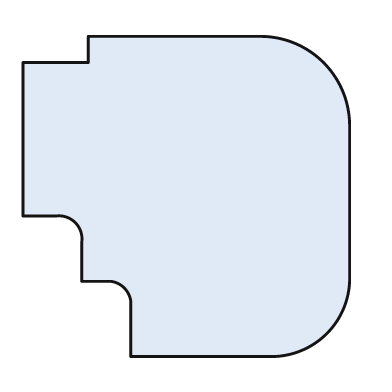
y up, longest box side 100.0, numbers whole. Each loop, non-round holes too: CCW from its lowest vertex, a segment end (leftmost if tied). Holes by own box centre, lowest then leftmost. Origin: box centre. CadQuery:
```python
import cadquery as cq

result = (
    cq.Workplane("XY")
    .moveTo(-17.0, -49.0)
    .lineTo(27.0, -49.0)
    .threePointArc((43.0, -42.0), (50.0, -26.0))
    .lineTo(50.0, 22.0)
    .threePointArc((42.0, 41.0), (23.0, 49.0))
    .lineTo(-30.0, 49.0)
    .lineTo(-30.0, 41.0)
    .lineTo(-50.0, 41.0)
    .lineTo(-50.0, -6.0)
    .lineTo(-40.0, -6.0)
    .threePointArc((-34.0, -8.0), (-32.0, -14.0))
    .lineTo(-32.0, -26.0)
    .lineTo(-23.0, -26.0)
    .threePointArc((-19.0, -28.0), (-17.0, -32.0))
    .close()
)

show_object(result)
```